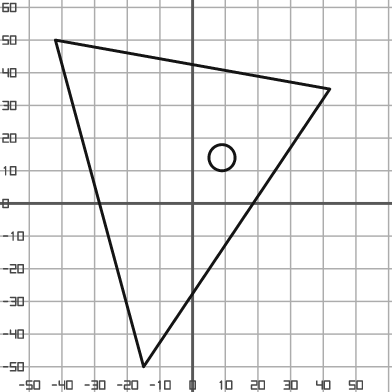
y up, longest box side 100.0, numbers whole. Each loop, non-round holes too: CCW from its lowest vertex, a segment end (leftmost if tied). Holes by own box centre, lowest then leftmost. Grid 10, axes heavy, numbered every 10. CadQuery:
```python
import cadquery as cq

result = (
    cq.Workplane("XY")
    .moveTo(-15.0, -50.0)
    .lineTo(42.0, 35.0)
    .lineTo(-42.0, 50.0)
    .close()
    .moveTo(9.0, 14.0)
    .circle(4.0)
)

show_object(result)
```